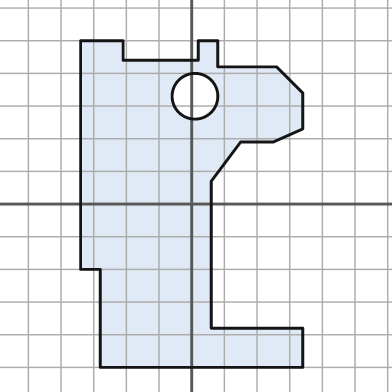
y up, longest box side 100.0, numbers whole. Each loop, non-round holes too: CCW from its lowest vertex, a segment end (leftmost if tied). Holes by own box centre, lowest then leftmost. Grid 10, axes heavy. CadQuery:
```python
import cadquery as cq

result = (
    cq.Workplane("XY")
    .moveTo(-28.0, -50.0)
    .lineTo(34.0, -50.0)
    .lineTo(34.0, -38.0)
    .lineTo(6.0, -38.0)
    .lineTo(6.0, 7.0)
    .lineTo(15.0, 19.0)
    .lineTo(25.0, 19.0)
    .lineTo(34.0, 23.0)
    .lineTo(34.0, 34.0)
    .lineTo(26.0, 42.0)
    .lineTo(8.0, 42.0)
    .lineTo(8.0, 50.0)
    .lineTo(2.0, 50.0)
    .lineTo(2.0, 44.0)
    .lineTo(-21.0, 44.0)
    .lineTo(-21.0, 50.0)
    .lineTo(-34.0, 50.0)
    .lineTo(-34.0, -20.0)
    .lineTo(-28.0, -20.0)
    .close()
    .moveTo(1.0, 33.0)
    .circle(7.0)
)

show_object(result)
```